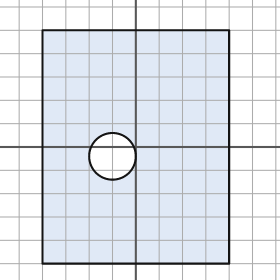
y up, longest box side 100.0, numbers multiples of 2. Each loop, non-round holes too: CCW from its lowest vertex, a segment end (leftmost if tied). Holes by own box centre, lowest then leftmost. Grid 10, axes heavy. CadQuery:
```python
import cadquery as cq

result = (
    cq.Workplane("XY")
    .moveTo(-40.0, -50.0)
    .lineTo(40.0, -50.0)
    .lineTo(40.0, 50.0)
    .lineTo(-40.0, 50.0)
    .close()
    .moveTo(-10.0, -4.0)
    .circle(10.0)
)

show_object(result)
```